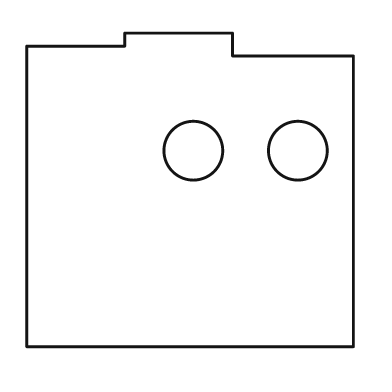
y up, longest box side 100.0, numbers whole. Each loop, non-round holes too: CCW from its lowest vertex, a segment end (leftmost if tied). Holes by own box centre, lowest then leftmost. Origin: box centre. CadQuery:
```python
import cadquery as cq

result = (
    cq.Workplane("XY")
    .moveTo(-50.0, -48.0)
    .lineTo(50.0, -48.0)
    .lineTo(50.0, 41.0)
    .lineTo(13.0, 41.0)
    .lineTo(13.0, 48.0)
    .lineTo(-20.0, 48.0)
    .lineTo(-20.0, 44.0)
    .lineTo(-50.0, 44.0)
    .close()
    .moveTo(1.0, 12.0)
    .circle(9.0)
    .moveTo(33.0, 12.0)
    .circle(9.0)
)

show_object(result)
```